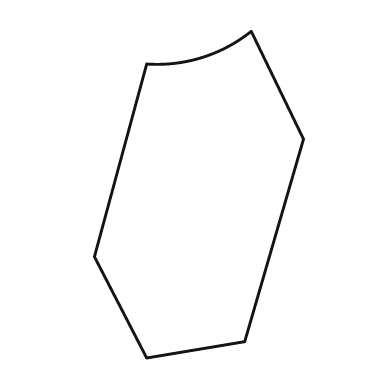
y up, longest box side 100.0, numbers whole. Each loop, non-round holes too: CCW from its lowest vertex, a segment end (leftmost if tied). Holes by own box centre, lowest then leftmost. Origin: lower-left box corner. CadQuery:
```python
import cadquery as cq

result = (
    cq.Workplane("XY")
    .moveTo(16.0, 0.0)
    .lineTo(46.0, 5.0)
    .lineTo(64.0, 67.0)
    .lineTo(48.0, 100.0)
    .threePointArc((33.0, 92.0), (16.0, 90.0))
    .lineTo(0.0, 31.0)
    .close()
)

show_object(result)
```